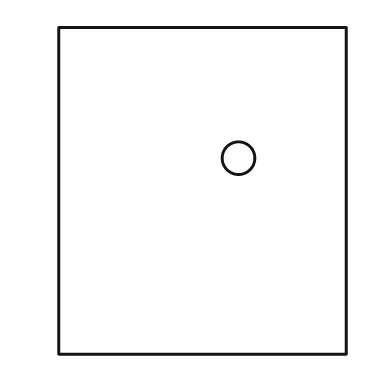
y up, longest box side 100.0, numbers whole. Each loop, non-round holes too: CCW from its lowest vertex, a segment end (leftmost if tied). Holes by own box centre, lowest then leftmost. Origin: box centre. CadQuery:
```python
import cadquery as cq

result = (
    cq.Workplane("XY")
    .moveTo(-44.0, -50.0)
    .lineTo(44.0, -50.0)
    .lineTo(44.0, 50.0)
    .lineTo(-44.0, 50.0)
    .close()
    .moveTo(11.0, 10.0)
    .circle(5.0)
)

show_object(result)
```